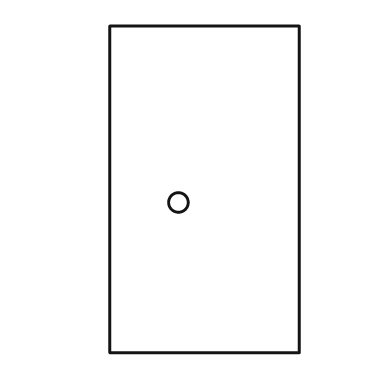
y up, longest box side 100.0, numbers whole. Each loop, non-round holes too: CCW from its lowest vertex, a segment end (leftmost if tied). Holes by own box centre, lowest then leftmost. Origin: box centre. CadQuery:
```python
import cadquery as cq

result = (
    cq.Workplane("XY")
    .moveTo(-29.0, -50.0)
    .lineTo(29.0, -50.0)
    .lineTo(29.0, 50.0)
    .lineTo(-29.0, 50.0)
    .close()
    .moveTo(-8.0, -4.0)
    .circle(3.0)
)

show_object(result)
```